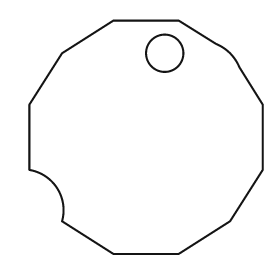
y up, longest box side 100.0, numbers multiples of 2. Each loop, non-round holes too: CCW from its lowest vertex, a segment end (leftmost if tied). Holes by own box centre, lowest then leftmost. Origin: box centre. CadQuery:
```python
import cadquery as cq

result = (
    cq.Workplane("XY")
    .moveTo(-14.0, -50.0)
    .lineTo(14.0, -50.0)
    .lineTo(36.0, -36.0)
    .lineTo(50.0, -14.0)
    .lineTo(50.0, 14.0)
    .lineTo(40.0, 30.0)
    .threePointArc((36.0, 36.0), (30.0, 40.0))
    .lineTo(14.0, 50.0)
    .lineTo(-14.0, 50.0)
    .lineTo(-36.0, 36.0)
    .lineTo(-50.0, 14.0)
    .lineTo(-50.0, -14.0)
    .threePointArc((-38.0, -22.0), (-36.0, -36.0))
    .close()
    .moveTo(8.0, 36.0)
    .circle(8.0)
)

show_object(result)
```